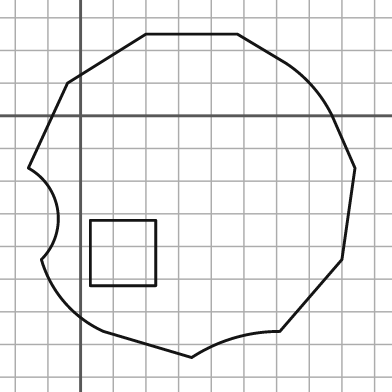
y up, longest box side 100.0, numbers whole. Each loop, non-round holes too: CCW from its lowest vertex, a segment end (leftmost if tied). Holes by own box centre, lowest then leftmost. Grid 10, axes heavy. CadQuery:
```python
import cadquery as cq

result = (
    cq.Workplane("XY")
    .moveTo(34.0, -74.0)
    .threePointArc((47.0, -68.0), (61.0, -66.0))
    .lineTo(80.0, -44.0)
    .lineTo(84.0, -16.0)
    .lineTo(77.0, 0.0)
    .threePointArc((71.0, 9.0), (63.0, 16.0))
    .lineTo(48.0, 25.0)
    .lineTo(20.0, 25.0)
    .lineTo(-4.0, 10.0)
    .lineTo(-16.0, -16.0)
    .threePointArc((-7.0, -29.0), (-12.0, -44.0))
    .threePointArc((-5.0, -57.0), (7.0, -66.0))
    .close()
    .moveTo(3.0, -52.0)
    .lineTo(23.0, -52.0)
    .lineTo(23.0, -32.0)
    .lineTo(3.0, -32.0)
    .close()
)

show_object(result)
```